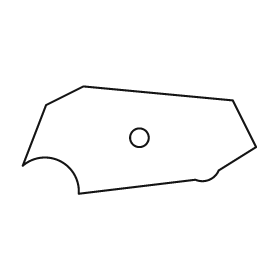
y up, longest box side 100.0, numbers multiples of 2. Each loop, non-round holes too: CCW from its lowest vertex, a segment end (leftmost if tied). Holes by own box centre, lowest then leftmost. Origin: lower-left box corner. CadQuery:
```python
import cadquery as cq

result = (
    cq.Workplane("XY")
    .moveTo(24.0, 0.0)
    .lineTo(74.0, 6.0)
    .threePointArc((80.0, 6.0), (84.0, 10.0))
    .lineTo(100.0, 20.0)
    .lineTo(90.0, 40.0)
    .lineTo(26.0, 46.0)
    .lineTo(10.0, 38.0)
    .lineTo(0.0, 12.0)
    .threePointArc((16.0, 14.0), (24.0, 0.0))
    .close()
    .moveTo(50.0, 24.0)
    .circle(4.0)
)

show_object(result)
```